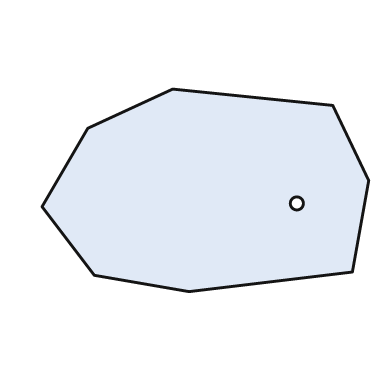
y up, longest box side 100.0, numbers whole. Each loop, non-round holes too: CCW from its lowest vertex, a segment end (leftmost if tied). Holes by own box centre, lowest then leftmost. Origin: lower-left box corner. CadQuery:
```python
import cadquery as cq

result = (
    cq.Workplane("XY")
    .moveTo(45.0, 0.0)
    .lineTo(95.0, 6.0)
    .lineTo(100.0, 34.0)
    .lineTo(89.0, 57.0)
    .lineTo(40.0, 62.0)
    .lineTo(14.0, 50.0)
    .lineTo(0.0, 26.0)
    .lineTo(16.0, 5.0)
    .close()
    .moveTo(78.0, 27.0)
    .circle(2.0)
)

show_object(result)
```